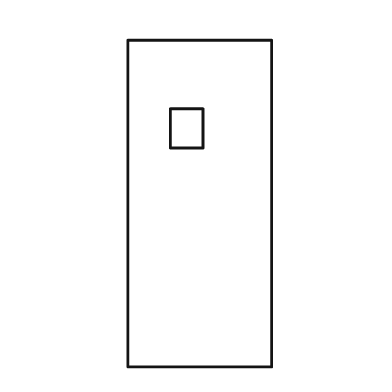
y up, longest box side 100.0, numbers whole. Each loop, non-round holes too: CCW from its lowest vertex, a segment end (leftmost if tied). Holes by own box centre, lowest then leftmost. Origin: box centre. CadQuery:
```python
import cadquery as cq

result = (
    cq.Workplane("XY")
    .moveTo(-22.0, -50.0)
    .lineTo(22.0, -50.0)
    .lineTo(22.0, 50.0)
    .lineTo(-22.0, 50.0)
    .close()
    .moveTo(-9.0, 17.0)
    .lineTo(1.0, 17.0)
    .lineTo(1.0, 29.0)
    .lineTo(-9.0, 29.0)
    .close()
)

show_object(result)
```